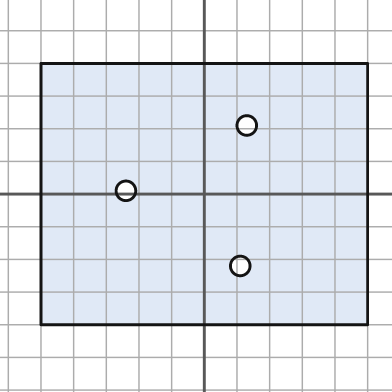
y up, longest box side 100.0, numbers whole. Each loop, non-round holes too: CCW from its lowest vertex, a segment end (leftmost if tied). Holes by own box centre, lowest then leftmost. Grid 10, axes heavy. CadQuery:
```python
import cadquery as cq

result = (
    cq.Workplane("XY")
    .moveTo(-50.0, -40.0)
    .lineTo(50.0, -40.0)
    .lineTo(50.0, 40.0)
    .lineTo(-50.0, 40.0)
    .close()
    .moveTo(11.0, -22.0)
    .circle(3.0)
    .moveTo(-24.0, 1.0)
    .circle(3.0)
    .moveTo(13.0, 21.0)
    .circle(3.0)
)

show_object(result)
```